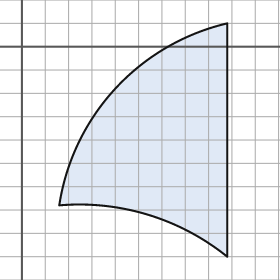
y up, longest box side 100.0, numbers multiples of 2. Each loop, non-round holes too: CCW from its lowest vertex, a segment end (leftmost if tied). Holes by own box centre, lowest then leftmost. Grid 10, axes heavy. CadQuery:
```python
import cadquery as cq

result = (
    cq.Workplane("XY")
    .moveTo(88.0, -90.0)
    .lineTo(88.0, 10.0)
    .threePointArc((40.0, -18.0), (16.0, -68.0))
    .threePointArc((54.0, -72.0), (88.0, -90.0))
    .close()
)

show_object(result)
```